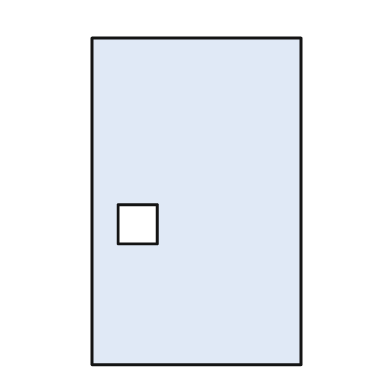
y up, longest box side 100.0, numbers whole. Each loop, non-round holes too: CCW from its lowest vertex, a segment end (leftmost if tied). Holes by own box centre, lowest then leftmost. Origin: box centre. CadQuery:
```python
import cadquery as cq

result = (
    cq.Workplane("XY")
    .moveTo(-32.0, -50.0)
    .lineTo(32.0, -50.0)
    .lineTo(32.0, 50.0)
    .lineTo(-32.0, 50.0)
    .close()
    .moveTo(-24.0, -13.0)
    .lineTo(-12.0, -13.0)
    .lineTo(-12.0, -1.0)
    .lineTo(-24.0, -1.0)
    .close()
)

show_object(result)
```